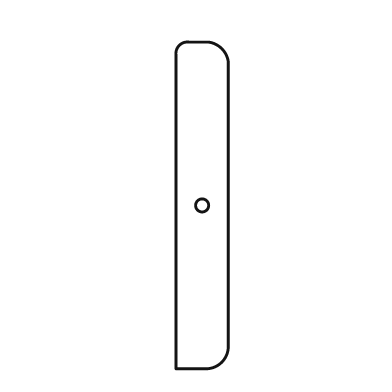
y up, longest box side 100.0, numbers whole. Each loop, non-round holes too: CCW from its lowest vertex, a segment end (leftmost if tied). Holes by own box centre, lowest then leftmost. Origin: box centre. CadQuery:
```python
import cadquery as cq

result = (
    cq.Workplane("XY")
    .moveTo(-8.0, -50.0)
    .lineTo(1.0, -50.0)
    .threePointArc((6.0, -48.0), (8.0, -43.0))
    .lineTo(8.0, 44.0)
    .threePointArc((6.0, 48.0), (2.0, 50.0))
    .lineTo(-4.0, 50.0)
    .threePointArc((-7.0, 49.0), (-8.0, 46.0))
    .close()
    .moveTo(0.0, 0.0)
    .circle(2.0)
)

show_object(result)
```